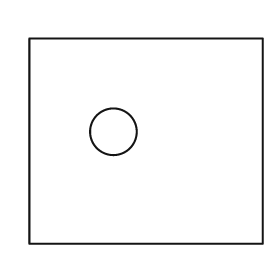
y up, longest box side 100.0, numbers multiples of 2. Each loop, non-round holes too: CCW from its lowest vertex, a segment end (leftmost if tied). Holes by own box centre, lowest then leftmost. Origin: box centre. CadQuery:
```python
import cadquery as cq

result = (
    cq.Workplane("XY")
    .moveTo(-50.0, -44.0)
    .lineTo(50.0, -44.0)
    .lineTo(50.0, 44.0)
    .lineTo(-50.0, 44.0)
    .close()
    .moveTo(-14.0, 4.0)
    .circle(10.0)
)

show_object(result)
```